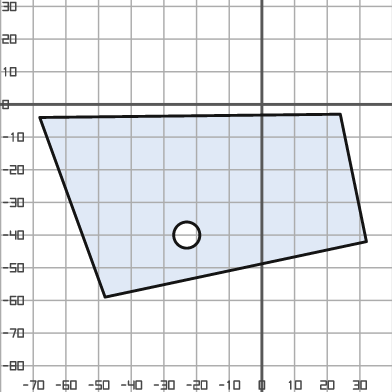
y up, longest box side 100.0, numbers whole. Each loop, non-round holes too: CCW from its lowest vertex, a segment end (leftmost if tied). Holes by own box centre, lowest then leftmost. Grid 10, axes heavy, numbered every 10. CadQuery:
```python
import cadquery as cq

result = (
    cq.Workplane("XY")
    .moveTo(-48.0, -59.0)
    .lineTo(32.0, -42.0)
    .lineTo(24.0, -3.0)
    .lineTo(-68.0, -4.0)
    .close()
    .moveTo(-23.0, -40.0)
    .circle(4.0)
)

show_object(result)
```